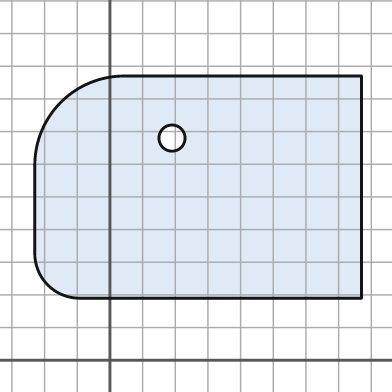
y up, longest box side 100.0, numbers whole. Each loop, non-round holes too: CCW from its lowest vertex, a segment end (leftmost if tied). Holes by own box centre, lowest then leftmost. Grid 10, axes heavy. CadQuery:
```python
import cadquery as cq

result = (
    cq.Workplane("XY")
    .moveTo(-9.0, 19.0)
    .lineTo(77.0, 19.0)
    .lineTo(77.0, 87.0)
    .lineTo(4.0, 87.0)
    .threePointArc((-15.0, 79.0), (-23.0, 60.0))
    .lineTo(-23.0, 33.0)
    .threePointArc((-19.0, 23.0), (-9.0, 19.0))
    .close()
    .moveTo(19.0, 68.0)
    .circle(4.0)
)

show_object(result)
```